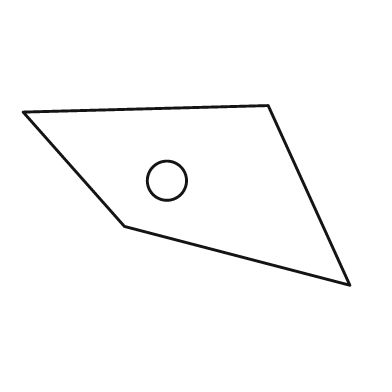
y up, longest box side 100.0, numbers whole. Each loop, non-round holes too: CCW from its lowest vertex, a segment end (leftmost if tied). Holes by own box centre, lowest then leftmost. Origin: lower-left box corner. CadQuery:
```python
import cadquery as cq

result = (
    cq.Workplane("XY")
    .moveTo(100.0, 0.0)
    .lineTo(75.0, 55.0)
    .lineTo(0.0, 53.0)
    .lineTo(31.0, 18.0)
    .close()
    .moveTo(44.0, 32.0)
    .circle(6.0)
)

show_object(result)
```